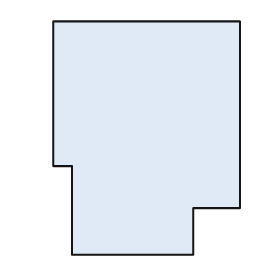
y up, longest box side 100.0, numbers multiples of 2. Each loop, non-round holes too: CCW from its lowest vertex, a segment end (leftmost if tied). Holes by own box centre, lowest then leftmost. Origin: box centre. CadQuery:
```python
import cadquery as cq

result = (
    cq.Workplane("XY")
    .moveTo(-32.0, -50.0)
    .lineTo(20.0, -50.0)
    .lineTo(20.0, -30.0)
    .lineTo(40.0, -30.0)
    .lineTo(40.0, 50.0)
    .lineTo(-40.0, 50.0)
    .lineTo(-40.0, -12.0)
    .lineTo(-32.0, -12.0)
    .close()
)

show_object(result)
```